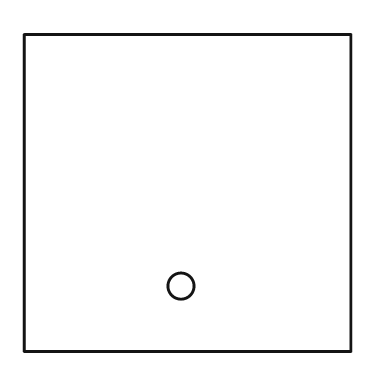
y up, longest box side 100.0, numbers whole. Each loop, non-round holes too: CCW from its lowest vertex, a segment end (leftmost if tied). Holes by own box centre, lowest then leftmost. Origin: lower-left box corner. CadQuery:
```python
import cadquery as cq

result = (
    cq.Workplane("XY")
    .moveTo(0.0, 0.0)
    .lineTo(100.0, 0.0)
    .lineTo(100.0, 97.0)
    .lineTo(0.0, 97.0)
    .close()
    .moveTo(48.0, 20.0)
    .circle(4.0)
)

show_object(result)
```